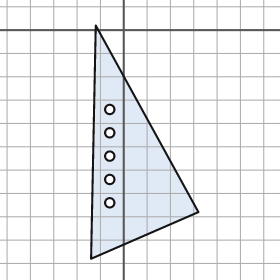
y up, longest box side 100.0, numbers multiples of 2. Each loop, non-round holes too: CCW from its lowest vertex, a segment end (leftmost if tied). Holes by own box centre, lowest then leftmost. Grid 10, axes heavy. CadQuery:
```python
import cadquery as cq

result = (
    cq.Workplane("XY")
    .moveTo(-14.0, -98.0)
    .lineTo(32.0, -78.0)
    .lineTo(-12.0, 2.0)
    .close()
    .moveTo(-6.0, -74.0)
    .circle(2.0)
    .moveTo(-6.0, -64.0)
    .circle(2.0)
    .moveTo(-6.0, -54.0)
    .circle(2.0)
    .moveTo(-6.0, -44.0)
    .circle(2.0)
    .moveTo(-6.0, -34.0)
    .circle(2.0)
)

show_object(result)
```